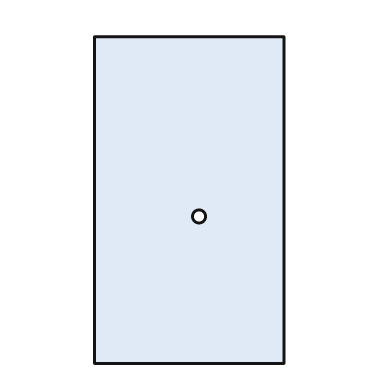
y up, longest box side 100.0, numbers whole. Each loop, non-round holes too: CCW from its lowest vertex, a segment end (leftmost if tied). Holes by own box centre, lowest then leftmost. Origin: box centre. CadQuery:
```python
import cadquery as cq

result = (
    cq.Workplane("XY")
    .moveTo(-29.0, -50.0)
    .lineTo(29.0, -50.0)
    .lineTo(29.0, 50.0)
    .lineTo(-29.0, 50.0)
    .close()
    .moveTo(3.0, -5.0)
    .circle(2.0)
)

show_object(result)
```